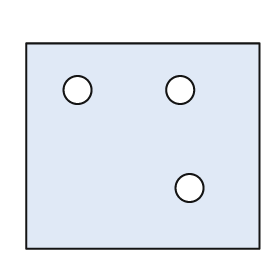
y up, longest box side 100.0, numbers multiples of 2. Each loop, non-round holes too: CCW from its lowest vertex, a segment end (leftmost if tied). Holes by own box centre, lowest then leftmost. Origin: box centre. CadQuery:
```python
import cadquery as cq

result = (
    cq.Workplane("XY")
    .moveTo(-50.0, -44.0)
    .lineTo(50.0, -44.0)
    .lineTo(50.0, 44.0)
    .lineTo(-50.0, 44.0)
    .close()
    .moveTo(20.0, -18.0)
    .circle(6.0)
    .moveTo(-28.0, 24.0)
    .circle(6.0)
    .moveTo(16.0, 24.0)
    .circle(6.0)
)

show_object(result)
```